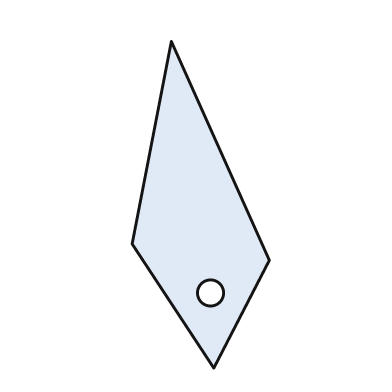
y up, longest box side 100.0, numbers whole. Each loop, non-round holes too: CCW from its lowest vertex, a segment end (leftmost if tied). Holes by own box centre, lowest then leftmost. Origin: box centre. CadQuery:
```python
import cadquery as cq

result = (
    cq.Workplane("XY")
    .moveTo(4.0, -50.0)
    .lineTo(21.0, -17.0)
    .lineTo(-9.0, 50.0)
    .lineTo(-21.0, -12.0)
    .close()
    .moveTo(3.0, -27.0)
    .circle(4.0)
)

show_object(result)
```